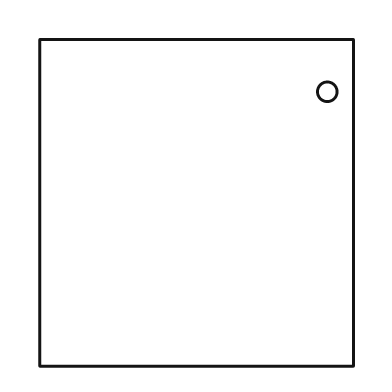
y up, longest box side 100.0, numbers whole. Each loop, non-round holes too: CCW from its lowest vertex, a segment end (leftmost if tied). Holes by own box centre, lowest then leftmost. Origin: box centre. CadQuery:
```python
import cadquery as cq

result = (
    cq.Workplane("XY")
    .moveTo(-48.0, -50.0)
    .lineTo(48.0, -50.0)
    .lineTo(48.0, 50.0)
    .lineTo(-48.0, 50.0)
    .close()
    .moveTo(40.0, 34.0)
    .circle(3.0)
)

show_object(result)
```